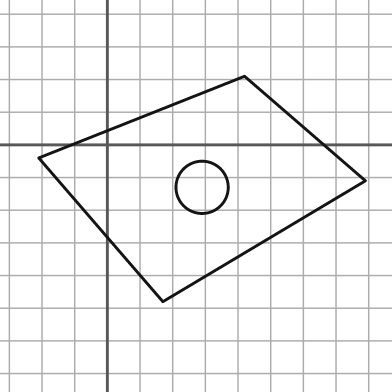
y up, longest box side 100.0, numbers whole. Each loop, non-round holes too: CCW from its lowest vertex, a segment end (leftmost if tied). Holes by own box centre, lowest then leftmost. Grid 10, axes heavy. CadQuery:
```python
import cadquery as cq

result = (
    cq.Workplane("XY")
    .moveTo(17.0, -48.0)
    .lineTo(79.0, -11.0)
    .lineTo(42.0, 21.0)
    .lineTo(-21.0, -4.0)
    .close()
    .moveTo(29.0, -13.0)
    .circle(8.0)
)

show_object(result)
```